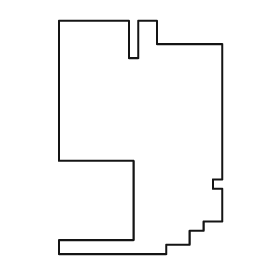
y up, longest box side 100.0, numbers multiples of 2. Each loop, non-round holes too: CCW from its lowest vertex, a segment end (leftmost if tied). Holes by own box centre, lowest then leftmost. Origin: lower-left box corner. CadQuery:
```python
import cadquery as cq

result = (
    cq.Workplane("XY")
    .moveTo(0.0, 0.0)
    .lineTo(46.0, 0.0)
    .lineTo(46.0, 4.0)
    .lineTo(56.0, 4.0)
    .lineTo(56.0, 10.0)
    .lineTo(62.0, 10.0)
    .lineTo(62.0, 14.0)
    .lineTo(70.0, 14.0)
    .lineTo(70.0, 28.0)
    .lineTo(66.0, 28.0)
    .lineTo(66.0, 32.0)
    .lineTo(70.0, 32.0)
    .lineTo(70.0, 90.0)
    .lineTo(42.0, 90.0)
    .lineTo(42.0, 100.0)
    .lineTo(34.0, 100.0)
    .lineTo(34.0, 84.0)
    .lineTo(30.0, 84.0)
    .lineTo(30.0, 100.0)
    .lineTo(0.0, 100.0)
    .lineTo(0.0, 40.0)
    .lineTo(32.0, 40.0)
    .lineTo(32.0, 6.0)
    .lineTo(0.0, 6.0)
    .close()
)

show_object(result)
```